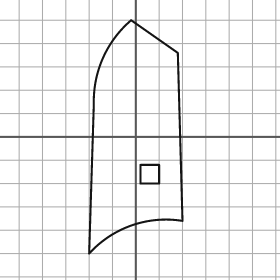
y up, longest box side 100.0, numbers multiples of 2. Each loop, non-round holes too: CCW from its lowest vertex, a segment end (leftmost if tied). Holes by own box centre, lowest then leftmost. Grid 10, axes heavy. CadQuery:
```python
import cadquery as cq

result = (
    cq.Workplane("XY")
    .moveTo(-20.0, -50.0)
    .threePointArc((-2.0, -38.0), (20.0, -36.0))
    .lineTo(18.0, 36.0)
    .lineTo(-2.0, 50.0)
    .threePointArc((-14.0, 34.0), (-18.0, 14.0))
    .close()
    .moveTo(2.0, -20.0)
    .lineTo(10.0, -20.0)
    .lineTo(10.0, -12.0)
    .lineTo(2.0, -12.0)
    .close()
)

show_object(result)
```